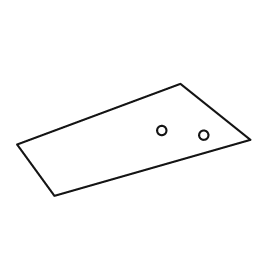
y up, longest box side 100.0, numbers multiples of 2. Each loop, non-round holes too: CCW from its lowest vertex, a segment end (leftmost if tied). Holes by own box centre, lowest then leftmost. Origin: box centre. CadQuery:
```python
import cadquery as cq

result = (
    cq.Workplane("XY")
    .moveTo(-34.0, -24.0)
    .lineTo(50.0, 0.0)
    .lineTo(20.0, 24.0)
    .lineTo(-50.0, -2.0)
    .close()
    .moveTo(30.0, 2.0)
    .circle(2.0)
    .moveTo(12.0, 4.0)
    .circle(2.0)
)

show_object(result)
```